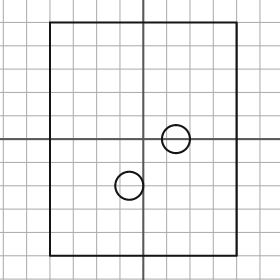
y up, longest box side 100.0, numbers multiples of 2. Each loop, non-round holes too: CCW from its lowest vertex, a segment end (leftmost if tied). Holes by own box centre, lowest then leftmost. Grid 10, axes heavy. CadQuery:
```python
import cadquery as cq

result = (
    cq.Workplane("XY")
    .moveTo(-40.0, -50.0)
    .lineTo(40.0, -50.0)
    .lineTo(40.0, 50.0)
    .lineTo(-40.0, 50.0)
    .close()
    .moveTo(-6.0, -20.0)
    .circle(6.0)
    .moveTo(14.0, 0.0)
    .circle(6.0)
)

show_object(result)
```